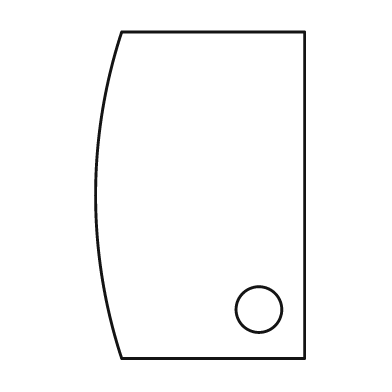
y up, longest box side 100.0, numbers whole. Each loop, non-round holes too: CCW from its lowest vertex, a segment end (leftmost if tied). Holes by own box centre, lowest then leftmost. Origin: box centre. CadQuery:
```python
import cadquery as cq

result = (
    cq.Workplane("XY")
    .moveTo(-24.0, -50.0)
    .lineTo(32.0, -50.0)
    .lineTo(32.0, 50.0)
    .lineTo(-24.0, 50.0)
    .threePointArc((-32.0, 0.0), (-24.0, -50.0))
    .close()
    .moveTo(18.0, -35.0)
    .circle(7.0)
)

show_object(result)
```